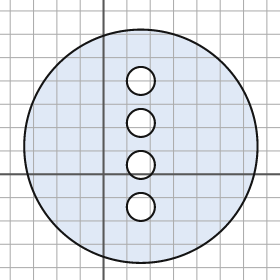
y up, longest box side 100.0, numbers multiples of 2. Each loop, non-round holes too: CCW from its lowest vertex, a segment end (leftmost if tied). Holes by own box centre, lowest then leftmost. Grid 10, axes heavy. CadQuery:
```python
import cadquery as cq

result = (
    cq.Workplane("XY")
    .moveTo(16.0, 12.0)
    .circle(50.0)
    .moveTo(16.0, -14.0)
    .circle(6.0)
    .moveTo(16.0, 4.0)
    .circle(6.0)
    .moveTo(16.0, 22.0)
    .circle(6.0)
    .moveTo(16.0, 40.0)
    .circle(6.0)
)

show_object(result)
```